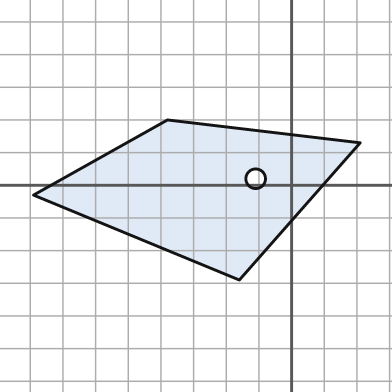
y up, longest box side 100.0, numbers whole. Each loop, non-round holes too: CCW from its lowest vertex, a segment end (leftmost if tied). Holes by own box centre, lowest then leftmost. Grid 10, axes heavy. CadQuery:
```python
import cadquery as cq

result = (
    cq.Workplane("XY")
    .moveTo(-16.0, -29.0)
    .lineTo(21.0, 13.0)
    .lineTo(-38.0, 20.0)
    .lineTo(-79.0, -3.0)
    .close()
    .moveTo(-11.0, 2.0)
    .circle(3.0)
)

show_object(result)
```